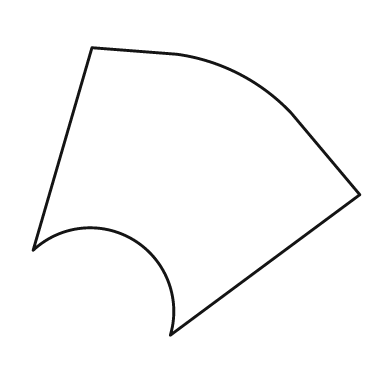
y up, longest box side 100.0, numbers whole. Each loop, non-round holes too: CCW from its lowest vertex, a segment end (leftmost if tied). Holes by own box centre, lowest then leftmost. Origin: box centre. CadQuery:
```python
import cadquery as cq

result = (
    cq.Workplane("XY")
    .moveTo(-8.0, -44.0)
    .lineTo(50.0, -1.0)
    .lineTo(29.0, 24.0)
    .threePointArc((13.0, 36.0), (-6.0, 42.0))
    .lineTo(-32.0, 44.0)
    .lineTo(-50.0, -18.0)
    .threePointArc((-19.0, -15.0), (-8.0, -44.0))
    .close()
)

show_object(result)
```